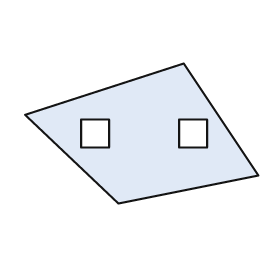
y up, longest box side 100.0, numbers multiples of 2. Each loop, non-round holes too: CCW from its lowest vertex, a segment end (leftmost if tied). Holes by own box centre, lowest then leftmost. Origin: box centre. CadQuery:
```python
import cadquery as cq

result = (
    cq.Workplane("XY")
    .moveTo(-10.0, -30.0)
    .lineTo(50.0, -18.0)
    .lineTo(18.0, 30.0)
    .lineTo(-50.0, 8.0)
    .close()
    .moveTo(-26.0, -6.0)
    .lineTo(-14.0, -6.0)
    .lineTo(-14.0, 6.0)
    .lineTo(-26.0, 6.0)
    .close()
    .moveTo(16.0, -6.0)
    .lineTo(28.0, -6.0)
    .lineTo(28.0, 6.0)
    .lineTo(16.0, 6.0)
    .close()
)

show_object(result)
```